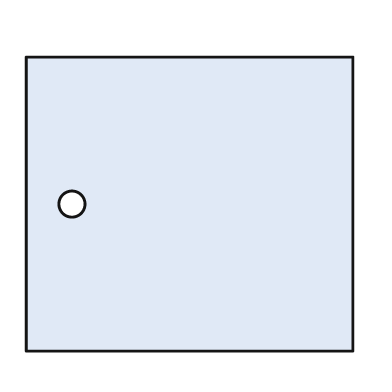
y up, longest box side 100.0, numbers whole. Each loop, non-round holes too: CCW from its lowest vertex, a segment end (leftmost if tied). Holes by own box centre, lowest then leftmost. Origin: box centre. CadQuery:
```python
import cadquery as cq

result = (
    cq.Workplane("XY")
    .moveTo(-50.0, -45.0)
    .lineTo(50.0, -45.0)
    .lineTo(50.0, 45.0)
    .lineTo(-50.0, 45.0)
    .close()
    .moveTo(-36.0, 0.0)
    .circle(4.0)
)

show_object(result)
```